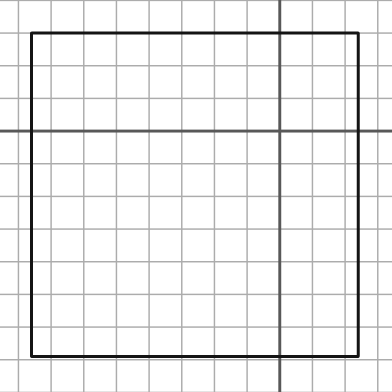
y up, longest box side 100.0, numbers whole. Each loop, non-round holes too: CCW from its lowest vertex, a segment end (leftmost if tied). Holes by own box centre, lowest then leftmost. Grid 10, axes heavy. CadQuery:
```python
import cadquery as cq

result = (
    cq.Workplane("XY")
    .moveTo(-76.0, -69.0)
    .lineTo(24.0, -69.0)
    .lineTo(24.0, 30.0)
    .lineTo(-76.0, 30.0)
    .close()
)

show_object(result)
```